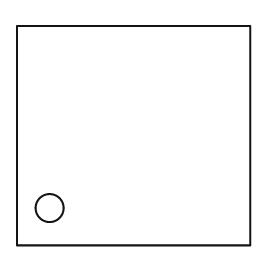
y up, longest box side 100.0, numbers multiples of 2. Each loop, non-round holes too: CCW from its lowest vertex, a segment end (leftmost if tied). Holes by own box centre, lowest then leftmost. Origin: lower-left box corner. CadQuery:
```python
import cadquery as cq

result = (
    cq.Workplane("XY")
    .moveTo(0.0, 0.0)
    .lineTo(100.0, 0.0)
    .lineTo(100.0, 94.0)
    .lineTo(0.0, 94.0)
    .close()
    .moveTo(14.0, 16.0)
    .circle(6.0)
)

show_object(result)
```